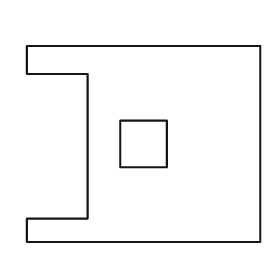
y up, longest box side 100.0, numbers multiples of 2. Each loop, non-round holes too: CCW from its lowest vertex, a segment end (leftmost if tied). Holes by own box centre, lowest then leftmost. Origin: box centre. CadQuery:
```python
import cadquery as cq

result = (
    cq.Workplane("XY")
    .moveTo(-50.0, -42.0)
    .lineTo(50.0, -42.0)
    .lineTo(50.0, 42.0)
    .lineTo(-50.0, 42.0)
    .lineTo(-50.0, 30.0)
    .lineTo(-24.0, 30.0)
    .lineTo(-24.0, -32.0)
    .lineTo(-50.0, -32.0)
    .close()
    .moveTo(-10.0, -10.0)
    .lineTo(10.0, -10.0)
    .lineTo(10.0, 10.0)
    .lineTo(-10.0, 10.0)
    .close()
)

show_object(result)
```